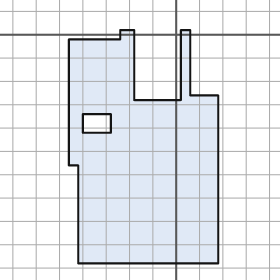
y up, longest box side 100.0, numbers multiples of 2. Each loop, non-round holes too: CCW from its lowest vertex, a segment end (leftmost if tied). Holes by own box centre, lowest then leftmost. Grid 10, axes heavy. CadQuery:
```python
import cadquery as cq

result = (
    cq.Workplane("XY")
    .moveTo(-42.0, -98.0)
    .lineTo(18.0, -98.0)
    .lineTo(18.0, -26.0)
    .lineTo(6.0, -26.0)
    .lineTo(6.0, 2.0)
    .lineTo(2.0, 2.0)
    .lineTo(2.0, -28.0)
    .lineTo(-18.0, -28.0)
    .lineTo(-18.0, 2.0)
    .lineTo(-24.0, 2.0)
    .lineTo(-24.0, -2.0)
    .lineTo(-46.0, -2.0)
    .lineTo(-46.0, -56.0)
    .lineTo(-42.0, -56.0)
    .close()
    .moveTo(-40.0, -42.0)
    .lineTo(-28.0, -42.0)
    .lineTo(-28.0, -34.0)
    .lineTo(-40.0, -34.0)
    .close()
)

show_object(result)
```